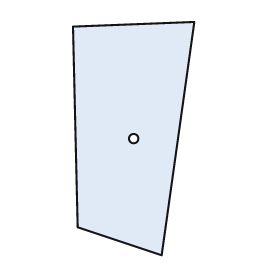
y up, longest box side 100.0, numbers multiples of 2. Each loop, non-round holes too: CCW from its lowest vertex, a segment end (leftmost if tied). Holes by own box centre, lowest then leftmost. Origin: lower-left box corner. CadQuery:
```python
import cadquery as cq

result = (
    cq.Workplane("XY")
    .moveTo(38.0, 0.0)
    .lineTo(52.0, 100.0)
    .lineTo(0.0, 98.0)
    .lineTo(2.0, 12.0)
    .close()
    .moveTo(26.0, 50.0)
    .circle(2.0)
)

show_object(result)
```